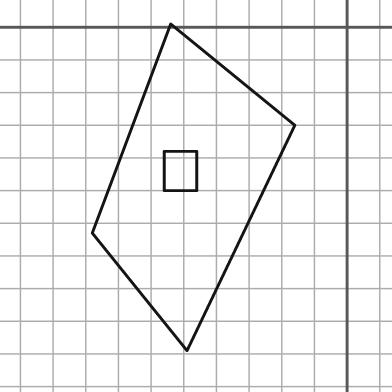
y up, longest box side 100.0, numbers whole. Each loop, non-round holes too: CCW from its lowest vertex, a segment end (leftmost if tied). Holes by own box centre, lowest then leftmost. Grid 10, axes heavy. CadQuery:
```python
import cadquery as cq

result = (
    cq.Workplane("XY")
    .moveTo(-49.0, -99.0)
    .lineTo(-16.0, -30.0)
    .lineTo(-54.0, 1.0)
    .lineTo(-78.0, -63.0)
    .close()
    .moveTo(-56.0, -50.0)
    .lineTo(-46.0, -50.0)
    .lineTo(-46.0, -38.0)
    .lineTo(-56.0, -38.0)
    .close()
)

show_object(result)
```